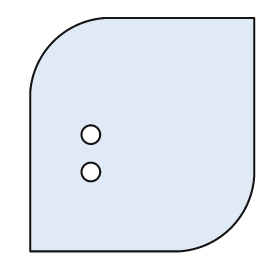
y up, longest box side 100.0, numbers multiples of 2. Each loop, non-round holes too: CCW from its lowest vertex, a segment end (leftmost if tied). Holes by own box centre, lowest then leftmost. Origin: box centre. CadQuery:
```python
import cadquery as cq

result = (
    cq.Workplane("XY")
    .moveTo(-48.0, -50.0)
    .lineTo(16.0, -50.0)
    .threePointArc((38.0, -40.0), (48.0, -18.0))
    .lineTo(48.0, 50.0)
    .lineTo(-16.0, 50.0)
    .threePointArc((-38.0, 40.0), (-48.0, 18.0))
    .close()
    .moveTo(-22.0, -16.0)
    .circle(4.0)
    .moveTo(-22.0, 0.0)
    .circle(4.0)
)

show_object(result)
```